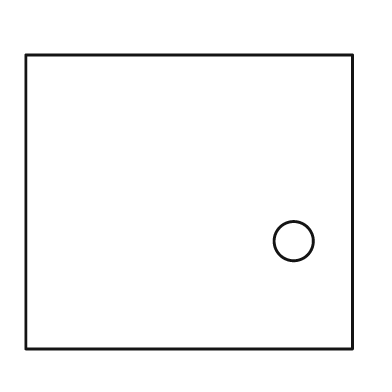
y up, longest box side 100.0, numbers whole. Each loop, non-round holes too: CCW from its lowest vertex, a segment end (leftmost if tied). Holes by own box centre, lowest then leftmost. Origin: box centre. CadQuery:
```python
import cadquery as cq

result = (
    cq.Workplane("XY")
    .moveTo(-50.0, -45.0)
    .lineTo(50.0, -45.0)
    .lineTo(50.0, 45.0)
    .lineTo(-50.0, 45.0)
    .close()
    .moveTo(32.0, -12.0)
    .circle(6.0)
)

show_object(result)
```